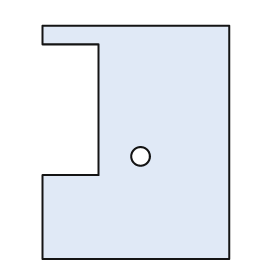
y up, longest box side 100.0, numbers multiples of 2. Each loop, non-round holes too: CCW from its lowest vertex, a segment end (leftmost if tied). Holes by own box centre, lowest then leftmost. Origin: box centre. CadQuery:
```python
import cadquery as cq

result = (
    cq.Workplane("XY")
    .moveTo(-40.0, -50.0)
    .lineTo(40.0, -50.0)
    .lineTo(40.0, 50.0)
    .lineTo(-40.0, 50.0)
    .lineTo(-40.0, 42.0)
    .lineTo(-16.0, 42.0)
    .lineTo(-16.0, -14.0)
    .lineTo(-40.0, -14.0)
    .close()
    .moveTo(2.0, -6.0)
    .circle(4.0)
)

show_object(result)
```